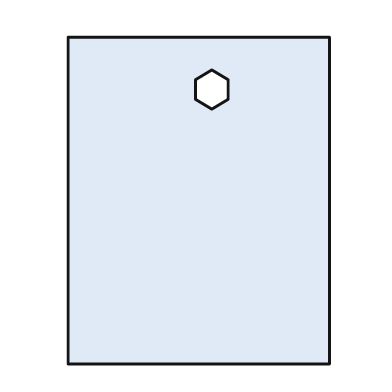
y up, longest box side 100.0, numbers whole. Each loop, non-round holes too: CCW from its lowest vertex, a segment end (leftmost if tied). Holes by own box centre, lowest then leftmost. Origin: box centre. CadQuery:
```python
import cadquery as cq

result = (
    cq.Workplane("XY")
    .moveTo(-40.0, -50.0)
    .lineTo(40.0, -50.0)
    .lineTo(40.0, 50.0)
    .lineTo(-40.0, 50.0)
    .close()
    .moveTo(4.0, 28.0)
    .lineTo(9.0, 31.0)
    .lineTo(9.0, 37.0)
    .lineTo(4.0, 40.0)
    .lineTo(-1.0, 37.0)
    .lineTo(-1.0, 31.0)
    .close()
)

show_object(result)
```